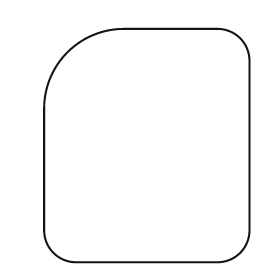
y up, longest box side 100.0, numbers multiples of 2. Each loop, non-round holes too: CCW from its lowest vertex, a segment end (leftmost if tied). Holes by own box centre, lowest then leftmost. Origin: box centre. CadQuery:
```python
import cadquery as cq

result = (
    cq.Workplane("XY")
    .moveTo(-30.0, -50.0)
    .lineTo(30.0, -50.0)
    .threePointArc((40.0, -46.0), (44.0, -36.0))
    .lineTo(44.0, 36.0)
    .threePointArc((40.0, 46.0), (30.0, 50.0))
    .lineTo(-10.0, 50.0)
    .threePointArc((-34.0, 40.0), (-44.0, 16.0))
    .lineTo(-44.0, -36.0)
    .threePointArc((-40.0, -46.0), (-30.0, -50.0))
    .close()
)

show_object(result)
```